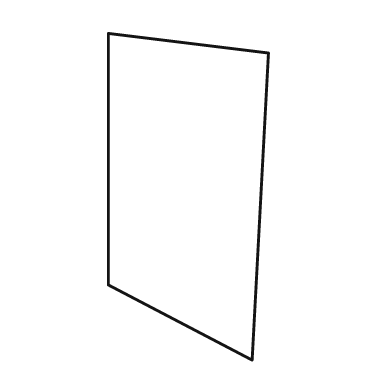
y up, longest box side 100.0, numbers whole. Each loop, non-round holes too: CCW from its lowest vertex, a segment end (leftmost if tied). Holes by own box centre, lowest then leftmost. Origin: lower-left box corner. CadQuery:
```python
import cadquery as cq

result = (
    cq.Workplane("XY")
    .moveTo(44.0, 0.0)
    .lineTo(49.0, 94.0)
    .lineTo(0.0, 100.0)
    .lineTo(0.0, 23.0)
    .close()
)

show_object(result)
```